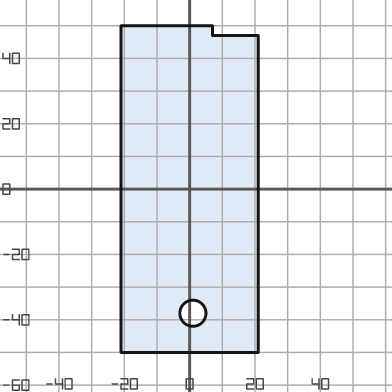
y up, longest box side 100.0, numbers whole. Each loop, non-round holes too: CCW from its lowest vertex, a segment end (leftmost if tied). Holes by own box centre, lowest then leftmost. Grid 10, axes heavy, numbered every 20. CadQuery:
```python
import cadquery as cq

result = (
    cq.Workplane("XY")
    .moveTo(-21.0, -50.0)
    .lineTo(21.0, -50.0)
    .lineTo(21.0, 47.0)
    .lineTo(7.0, 47.0)
    .lineTo(7.0, 50.0)
    .lineTo(-21.0, 50.0)
    .close()
    .moveTo(1.0, -38.0)
    .circle(4.0)
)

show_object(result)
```